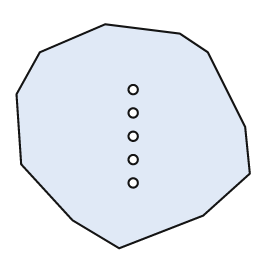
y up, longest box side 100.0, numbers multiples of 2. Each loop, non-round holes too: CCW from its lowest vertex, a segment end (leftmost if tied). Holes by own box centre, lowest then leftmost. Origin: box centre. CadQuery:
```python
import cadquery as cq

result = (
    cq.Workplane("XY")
    .moveTo(-6.0, -48.0)
    .lineTo(30.0, -34.0)
    .lineTo(50.0, -16.0)
    .lineTo(48.0, 4.0)
    .lineTo(32.0, 36.0)
    .lineTo(20.0, 44.0)
    .lineTo(-12.0, 48.0)
    .lineTo(-40.0, 36.0)
    .lineTo(-50.0, 18.0)
    .lineTo(-48.0, -12.0)
    .lineTo(-26.0, -36.0)
    .close()
    .moveTo(0.0, -20.0)
    .circle(2.0)
    .moveTo(0.0, -10.0)
    .circle(2.0)
    .moveTo(0.0, 0.0)
    .circle(2.0)
    .moveTo(0.0, 10.0)
    .circle(2.0)
    .moveTo(0.0, 20.0)
    .circle(2.0)
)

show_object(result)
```